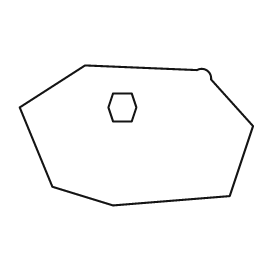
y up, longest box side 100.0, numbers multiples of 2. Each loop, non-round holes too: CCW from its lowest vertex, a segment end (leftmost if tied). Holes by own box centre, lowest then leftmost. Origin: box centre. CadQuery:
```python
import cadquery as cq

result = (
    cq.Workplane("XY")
    .moveTo(-10.0, -30.0)
    .lineTo(40.0, -26.0)
    .lineTo(50.0, 4.0)
    .lineTo(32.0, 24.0)
    .threePointArc((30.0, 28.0), (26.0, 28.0))
    .lineTo(-22.0, 30.0)
    .lineTo(-50.0, 12.0)
    .lineTo(-36.0, -22.0)
    .close()
    .moveTo(-10.0, 6.0)
    .lineTo(-2.0, 6.0)
    .lineTo(0.0, 12.0)
    .lineTo(-2.0, 18.0)
    .lineTo(-10.0, 18.0)
    .lineTo(-12.0, 12.0)
    .close()
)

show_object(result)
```